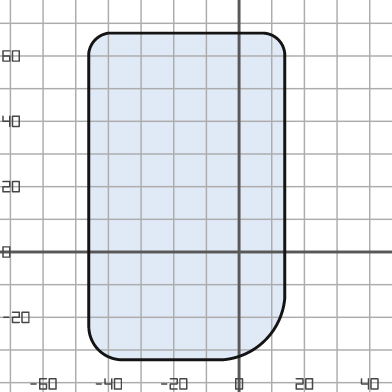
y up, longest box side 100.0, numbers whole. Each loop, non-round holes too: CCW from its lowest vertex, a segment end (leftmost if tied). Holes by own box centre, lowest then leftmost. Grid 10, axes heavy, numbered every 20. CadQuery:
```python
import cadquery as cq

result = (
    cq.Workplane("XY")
    .moveTo(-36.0, -33.0)
    .lineTo(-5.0, -33.0)
    .threePointArc((8.0, -27.0), (14.0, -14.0))
    .lineTo(14.0, 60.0)
    .threePointArc((12.0, 65.0), (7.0, 67.0))
    .lineTo(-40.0, 67.0)
    .threePointArc((-44.0, 65.0), (-46.0, 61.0))
    .lineTo(-46.0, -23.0)
    .threePointArc((-43.0, -30.0), (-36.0, -33.0))
    .close()
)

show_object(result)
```